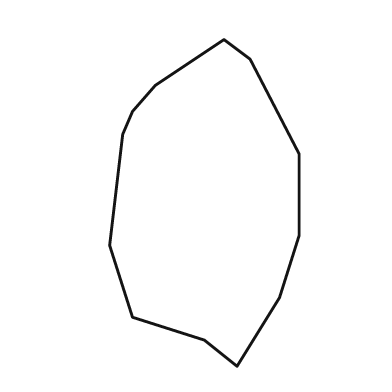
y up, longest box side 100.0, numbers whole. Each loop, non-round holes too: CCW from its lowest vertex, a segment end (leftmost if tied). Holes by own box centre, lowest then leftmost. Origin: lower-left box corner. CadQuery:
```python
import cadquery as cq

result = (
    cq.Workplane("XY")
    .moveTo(39.0, 0.0)
    .lineTo(52.0, 21.0)
    .lineTo(58.0, 40.0)
    .lineTo(58.0, 65.0)
    .lineTo(43.0, 94.0)
    .lineTo(35.0, 100.0)
    .lineTo(14.0, 86.0)
    .lineTo(7.0, 78.0)
    .lineTo(4.0, 71.0)
    .lineTo(0.0, 37.0)
    .lineTo(7.0, 15.0)
    .lineTo(29.0, 8.0)
    .close()
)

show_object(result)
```